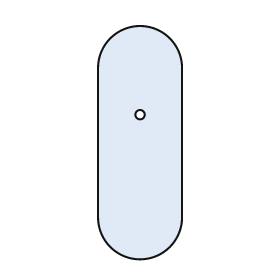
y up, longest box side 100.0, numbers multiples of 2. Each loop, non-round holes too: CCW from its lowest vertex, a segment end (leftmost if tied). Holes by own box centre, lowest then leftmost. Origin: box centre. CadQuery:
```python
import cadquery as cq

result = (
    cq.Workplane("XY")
    .moveTo(-18.0, -32.0)
    .threePointArc((0.0, -50.0), (18.0, -32.0))
    .lineTo(18.0, 32.0)
    .threePointArc((0.0, 50.0), (-18.0, 32.0))
    .close()
    .moveTo(0.0, 12.0)
    .circle(2.0)
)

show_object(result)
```